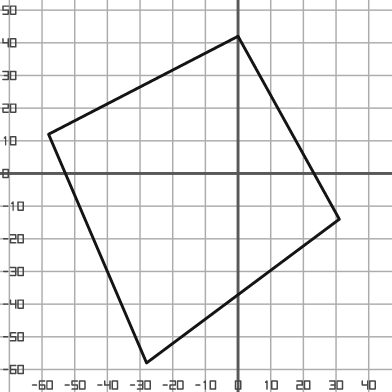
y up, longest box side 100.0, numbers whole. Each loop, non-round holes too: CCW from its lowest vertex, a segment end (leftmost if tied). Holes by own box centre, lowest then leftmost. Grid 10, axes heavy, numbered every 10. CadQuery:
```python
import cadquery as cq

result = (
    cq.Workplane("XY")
    .moveTo(-28.0, -58.0)
    .lineTo(31.0, -14.0)
    .lineTo(0.0, 42.0)
    .lineTo(-58.0, 12.0)
    .close()
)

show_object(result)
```